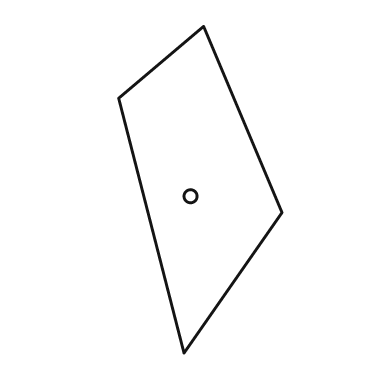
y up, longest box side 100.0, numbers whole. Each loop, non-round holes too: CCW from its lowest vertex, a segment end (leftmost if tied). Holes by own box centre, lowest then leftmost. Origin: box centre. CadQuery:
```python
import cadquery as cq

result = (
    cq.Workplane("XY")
    .moveTo(-5.0, -50.0)
    .lineTo(25.0, -7.0)
    .lineTo(1.0, 50.0)
    .lineTo(-25.0, 28.0)
    .close()
    .moveTo(-3.0, -2.0)
    .circle(2.0)
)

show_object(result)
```